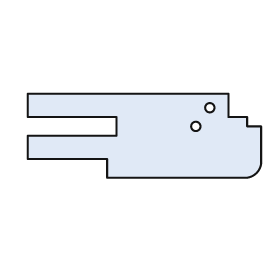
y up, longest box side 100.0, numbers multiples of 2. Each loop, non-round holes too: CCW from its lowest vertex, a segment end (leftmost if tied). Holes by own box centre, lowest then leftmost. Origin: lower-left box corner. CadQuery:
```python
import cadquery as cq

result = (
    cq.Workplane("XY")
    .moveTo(34.0, 0.0)
    .lineTo(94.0, 0.0)
    .threePointArc((98.0, 2.0), (100.0, 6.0))
    .lineTo(100.0, 22.0)
    .lineTo(94.0, 22.0)
    .lineTo(94.0, 26.0)
    .lineTo(86.0, 26.0)
    .lineTo(86.0, 36.0)
    .lineTo(0.0, 36.0)
    .lineTo(0.0, 26.0)
    .lineTo(38.0, 26.0)
    .lineTo(38.0, 18.0)
    .lineTo(0.0, 18.0)
    .lineTo(0.0, 8.0)
    .lineTo(34.0, 8.0)
    .close()
    .moveTo(72.0, 22.0)
    .circle(2.0)
    .moveTo(78.0, 30.0)
    .circle(2.0)
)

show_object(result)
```